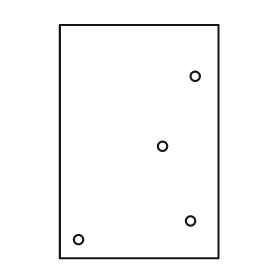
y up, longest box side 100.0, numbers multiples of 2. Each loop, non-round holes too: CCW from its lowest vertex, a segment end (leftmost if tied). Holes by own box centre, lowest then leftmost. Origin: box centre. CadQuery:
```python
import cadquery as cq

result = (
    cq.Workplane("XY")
    .moveTo(-34.0, -50.0)
    .lineTo(34.0, -50.0)
    .lineTo(34.0, 50.0)
    .lineTo(-34.0, 50.0)
    .close()
    .moveTo(-26.0, -42.0)
    .circle(2.0)
    .moveTo(22.0, -34.0)
    .circle(2.0)
    .moveTo(10.0, -2.0)
    .circle(2.0)
    .moveTo(24.0, 28.0)
    .circle(2.0)
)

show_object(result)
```